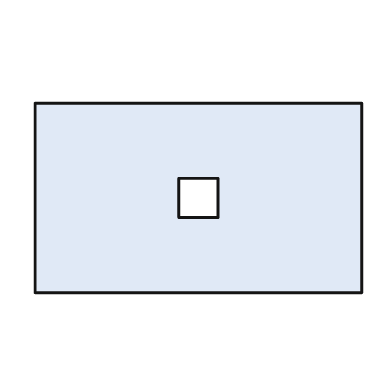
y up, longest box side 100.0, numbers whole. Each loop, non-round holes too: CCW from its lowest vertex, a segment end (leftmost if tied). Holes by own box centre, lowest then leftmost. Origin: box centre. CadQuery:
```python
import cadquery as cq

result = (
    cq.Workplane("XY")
    .moveTo(-50.0, -29.0)
    .lineTo(50.0, -29.0)
    .lineTo(50.0, 29.0)
    .lineTo(-50.0, 29.0)
    .close()
    .moveTo(-6.0, -6.0)
    .lineTo(6.0, -6.0)
    .lineTo(6.0, 6.0)
    .lineTo(-6.0, 6.0)
    .close()
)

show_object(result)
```